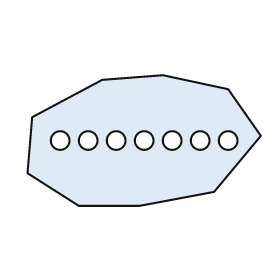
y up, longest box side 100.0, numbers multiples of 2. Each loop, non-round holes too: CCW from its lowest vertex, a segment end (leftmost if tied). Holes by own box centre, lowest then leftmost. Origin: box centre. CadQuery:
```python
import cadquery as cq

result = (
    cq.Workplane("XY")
    .moveTo(-28.0, -28.0)
    .lineTo(-2.0, -28.0)
    .lineTo(30.0, -22.0)
    .lineTo(50.0, 2.0)
    .lineTo(36.0, 22.0)
    .lineTo(8.0, 28.0)
    .lineTo(-18.0, 26.0)
    .lineTo(-48.0, 10.0)
    .lineTo(-50.0, -14.0)
    .close()
    .moveTo(-36.0, 0.0)
    .circle(4.0)
    .moveTo(-24.0, 0.0)
    .circle(4.0)
    .moveTo(-12.0, 0.0)
    .circle(4.0)
    .moveTo(0.0, 0.0)
    .circle(4.0)
    .moveTo(12.0, 0.0)
    .circle(4.0)
    .moveTo(24.0, 0.0)
    .circle(4.0)
    .moveTo(36.0, 0.0)
    .circle(4.0)
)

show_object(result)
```